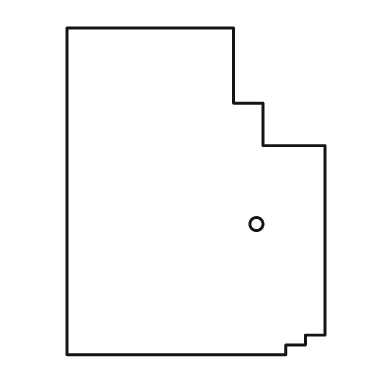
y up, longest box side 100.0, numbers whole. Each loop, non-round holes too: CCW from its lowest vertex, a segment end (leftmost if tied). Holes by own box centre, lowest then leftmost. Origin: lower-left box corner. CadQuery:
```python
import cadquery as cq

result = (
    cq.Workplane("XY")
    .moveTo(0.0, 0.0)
    .lineTo(67.0, 0.0)
    .lineTo(67.0, 3.0)
    .lineTo(73.0, 3.0)
    .lineTo(73.0, 6.0)
    .lineTo(79.0, 6.0)
    .lineTo(79.0, 64.0)
    .lineTo(60.0, 64.0)
    .lineTo(60.0, 77.0)
    .lineTo(51.0, 77.0)
    .lineTo(51.0, 100.0)
    .lineTo(0.0, 100.0)
    .close()
    .moveTo(58.0, 40.0)
    .circle(2.0)
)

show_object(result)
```